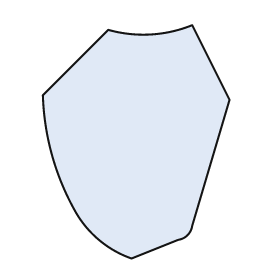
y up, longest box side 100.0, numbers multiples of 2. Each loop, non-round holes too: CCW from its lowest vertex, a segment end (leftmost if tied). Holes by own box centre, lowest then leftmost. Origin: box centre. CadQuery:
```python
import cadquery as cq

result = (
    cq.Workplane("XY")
    .moveTo(-2.0, -50.0)
    .lineTo(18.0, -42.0)
    .threePointArc((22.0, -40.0), (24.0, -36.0))
    .lineTo(40.0, 18.0)
    .lineTo(24.0, 50.0)
    .threePointArc((6.0, 46.0), (-12.0, 48.0))
    .lineTo(-40.0, 20.0)
    .threePointArc((-36.0, -6.0), (-26.0, -30.0))
    .threePointArc((-16.0, -42.0), (-2.0, -50.0))
    .close()
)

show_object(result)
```